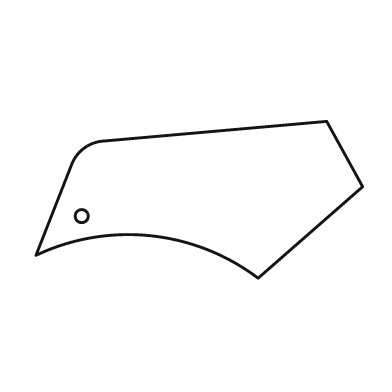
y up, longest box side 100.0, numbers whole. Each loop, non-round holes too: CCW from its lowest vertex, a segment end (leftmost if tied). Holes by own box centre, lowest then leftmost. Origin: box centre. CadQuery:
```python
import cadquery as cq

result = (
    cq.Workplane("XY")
    .moveTo(18.0, -24.0)
    .lineTo(50.0, 4.0)
    .lineTo(39.0, 24.0)
    .lineTo(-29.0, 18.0)
    .threePointArc((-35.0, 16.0), (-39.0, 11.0))
    .lineTo(-50.0, -17.0)
    .threePointArc((-15.0, -11.0), (18.0, -24.0))
    .close()
    .moveTo(-36.0, -5.0)
    .circle(2.0)
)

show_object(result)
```